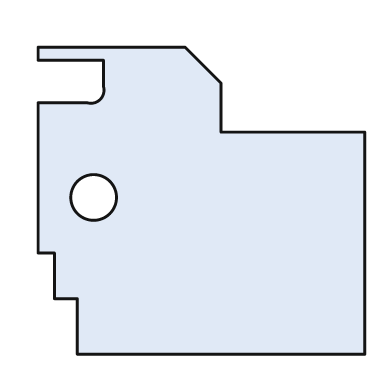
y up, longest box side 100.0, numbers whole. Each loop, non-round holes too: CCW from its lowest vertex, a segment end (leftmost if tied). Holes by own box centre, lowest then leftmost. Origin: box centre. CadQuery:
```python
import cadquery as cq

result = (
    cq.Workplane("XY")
    .moveTo(-38.0, -47.0)
    .lineTo(50.0, -47.0)
    .lineTo(50.0, 21.0)
    .lineTo(6.0, 21.0)
    .lineTo(6.0, 36.0)
    .lineTo(-5.0, 47.0)
    .lineTo(-50.0, 47.0)
    .lineTo(-50.0, 43.0)
    .lineTo(-30.0, 43.0)
    .lineTo(-30.0, 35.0)
    .threePointArc((-31.0, 31.0), (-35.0, 30.0))
    .lineTo(-50.0, 30.0)
    .lineTo(-50.0, -16.0)
    .lineTo(-45.0, -16.0)
    .lineTo(-45.0, -30.0)
    .lineTo(-38.0, -30.0)
    .close()
    .moveTo(-33.0, 1.0)
    .circle(7.0)
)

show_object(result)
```